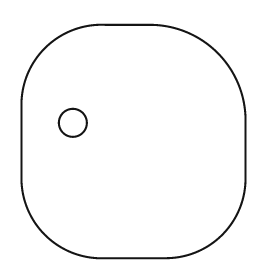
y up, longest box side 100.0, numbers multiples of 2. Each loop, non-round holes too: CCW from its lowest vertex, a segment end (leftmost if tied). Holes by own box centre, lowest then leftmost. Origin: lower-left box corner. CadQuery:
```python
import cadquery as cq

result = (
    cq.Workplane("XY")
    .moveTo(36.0, 0.0)
    .lineTo(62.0, 0.0)
    .threePointArc((86.0, 10.0), (96.0, 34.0))
    .lineTo(96.0, 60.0)
    .threePointArc((84.0, 88.0), (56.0, 100.0))
    .lineTo(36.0, 100.0)
    .threePointArc((10.0, 90.0), (0.0, 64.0))
    .lineTo(0.0, 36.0)
    .threePointArc((10.0, 10.0), (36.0, 0.0))
    .close()
    .moveTo(22.0, 58.0)
    .circle(6.0)
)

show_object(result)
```